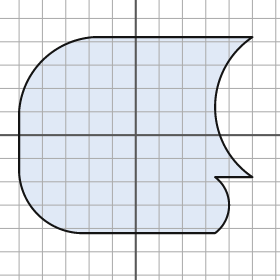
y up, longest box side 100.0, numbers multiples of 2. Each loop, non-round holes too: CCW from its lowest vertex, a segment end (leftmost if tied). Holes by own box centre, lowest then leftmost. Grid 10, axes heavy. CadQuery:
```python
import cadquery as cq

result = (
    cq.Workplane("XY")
    .moveTo(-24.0, -42.0)
    .lineTo(34.0, -42.0)
    .threePointArc((40.0, -30.0), (34.0, -18.0))
    .lineTo(50.0, -18.0)
    .threePointArc((34.0, 12.0), (50.0, 42.0))
    .lineTo(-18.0, 42.0)
    .threePointArc((-40.0, 32.0), (-50.0, 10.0))
    .lineTo(-50.0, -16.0)
    .threePointArc((-42.0, -34.0), (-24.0, -42.0))
    .close()
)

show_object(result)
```